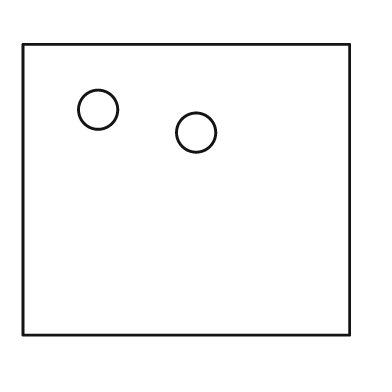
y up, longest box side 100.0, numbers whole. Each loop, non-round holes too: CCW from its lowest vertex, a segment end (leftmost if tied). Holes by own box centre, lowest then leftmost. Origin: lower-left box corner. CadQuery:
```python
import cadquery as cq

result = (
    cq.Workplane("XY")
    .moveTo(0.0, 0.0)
    .lineTo(100.0, 0.0)
    .lineTo(100.0, 89.0)
    .lineTo(0.0, 89.0)
    .close()
    .moveTo(53.0, 62.0)
    .circle(6.0)
    .moveTo(23.0, 69.0)
    .circle(6.0)
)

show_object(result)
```